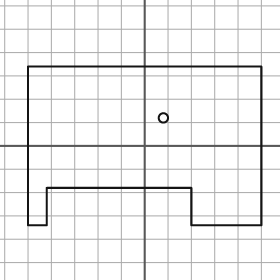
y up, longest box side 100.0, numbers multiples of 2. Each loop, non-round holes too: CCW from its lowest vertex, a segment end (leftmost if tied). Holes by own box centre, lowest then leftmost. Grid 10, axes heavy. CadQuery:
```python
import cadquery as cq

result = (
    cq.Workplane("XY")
    .moveTo(-50.0, -34.0)
    .lineTo(-42.0, -34.0)
    .lineTo(-42.0, -18.0)
    .lineTo(20.0, -18.0)
    .lineTo(20.0, -34.0)
    .lineTo(50.0, -34.0)
    .lineTo(50.0, 34.0)
    .lineTo(-50.0, 34.0)
    .close()
    .moveTo(8.0, 12.0)
    .circle(2.0)
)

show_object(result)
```